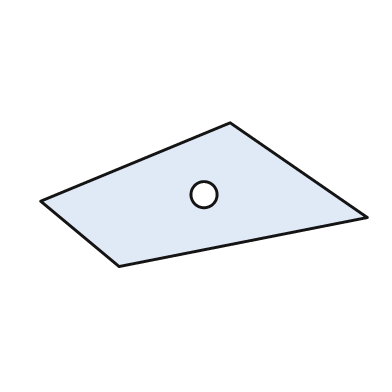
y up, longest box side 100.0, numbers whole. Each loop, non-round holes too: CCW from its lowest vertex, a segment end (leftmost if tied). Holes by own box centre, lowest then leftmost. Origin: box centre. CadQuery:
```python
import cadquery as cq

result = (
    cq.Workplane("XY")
    .moveTo(-26.0, -22.0)
    .lineTo(50.0, -7.0)
    .lineTo(8.0, 22.0)
    .lineTo(-50.0, -2.0)
    .close()
    .moveTo(0.0, 0.0)
    .circle(4.0)
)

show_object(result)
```